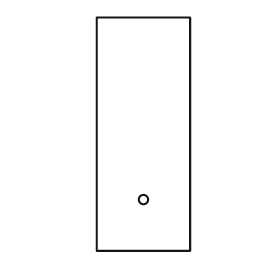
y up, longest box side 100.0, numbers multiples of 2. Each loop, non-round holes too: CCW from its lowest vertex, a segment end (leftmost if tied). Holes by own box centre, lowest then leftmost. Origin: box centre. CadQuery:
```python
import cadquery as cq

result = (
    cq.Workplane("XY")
    .moveTo(-20.0, -50.0)
    .lineTo(20.0, -50.0)
    .lineTo(20.0, 50.0)
    .lineTo(-20.0, 50.0)
    .close()
    .moveTo(0.0, -28.0)
    .circle(2.0)
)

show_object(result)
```